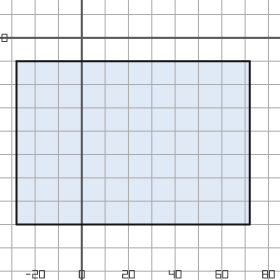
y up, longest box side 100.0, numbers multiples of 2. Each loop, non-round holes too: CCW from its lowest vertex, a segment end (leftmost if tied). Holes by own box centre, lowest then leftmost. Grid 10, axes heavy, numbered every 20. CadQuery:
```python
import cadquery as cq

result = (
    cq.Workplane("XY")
    .moveTo(-28.0, -80.0)
    .lineTo(72.0, -80.0)
    .lineTo(72.0, -10.0)
    .lineTo(-28.0, -10.0)
    .close()
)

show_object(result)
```